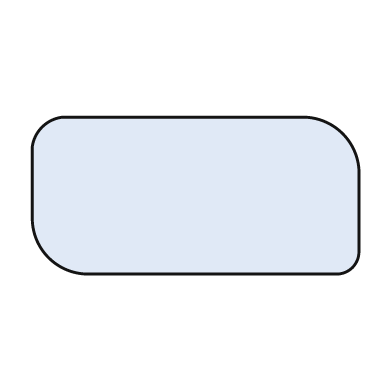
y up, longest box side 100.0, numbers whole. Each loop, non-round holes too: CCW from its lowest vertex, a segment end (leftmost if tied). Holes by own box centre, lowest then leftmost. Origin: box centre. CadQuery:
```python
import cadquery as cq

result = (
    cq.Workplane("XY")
    .moveTo(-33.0, -24.0)
    .lineTo(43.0, -24.0)
    .threePointArc((48.0, -22.0), (50.0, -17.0))
    .lineTo(50.0, 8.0)
    .threePointArc((45.0, 19.0), (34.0, 24.0))
    .lineTo(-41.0, 24.0)
    .threePointArc((-47.0, 21.0), (-50.0, 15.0))
    .lineTo(-50.0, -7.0)
    .threePointArc((-45.0, -19.0), (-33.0, -24.0))
    .close()
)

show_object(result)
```